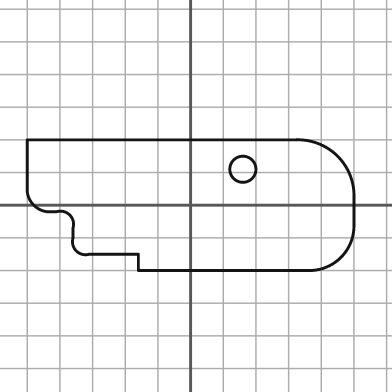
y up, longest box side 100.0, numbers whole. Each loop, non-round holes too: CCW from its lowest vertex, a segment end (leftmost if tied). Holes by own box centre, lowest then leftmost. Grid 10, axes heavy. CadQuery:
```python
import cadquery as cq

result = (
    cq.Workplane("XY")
    .moveTo(-16.0, -20.0)
    .lineTo(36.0, -20.0)
    .threePointArc((46.0, -16.0), (50.0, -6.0))
    .lineTo(50.0, 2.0)
    .threePointArc((45.0, 15.0), (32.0, 20.0))
    .lineTo(-50.0, 20.0)
    .lineTo(-50.0, 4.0)
    .threePointArc((-48.0, 0.0), (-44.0, -2.0))
    .lineTo(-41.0, -2.0)
    .threePointArc((-37.0, -3.0), (-36.0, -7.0))
    .lineTo(-36.0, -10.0)
    .threePointArc((-35.0, -14.0), (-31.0, -15.0))
    .lineTo(-16.0, -15.0)
    .close()
    .moveTo(16.0, 11.0)
    .circle(4.0)
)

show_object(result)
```